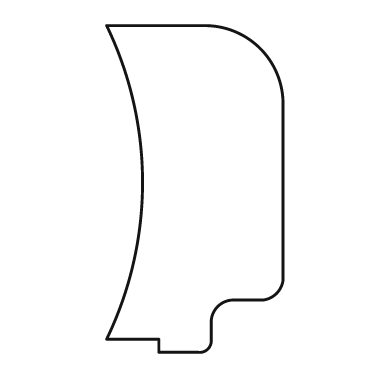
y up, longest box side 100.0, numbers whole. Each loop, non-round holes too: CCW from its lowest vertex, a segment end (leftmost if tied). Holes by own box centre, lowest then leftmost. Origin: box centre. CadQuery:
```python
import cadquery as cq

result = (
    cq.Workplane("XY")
    .moveTo(-11.0, -50.0)
    .lineTo(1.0, -50.0)
    .threePointArc((4.0, -49.0), (5.0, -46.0))
    .lineTo(5.0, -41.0)
    .threePointArc((7.0, -36.0), (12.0, -34.0))
    .lineTo(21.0, -34.0)
    .threePointArc((25.0, -32.0), (27.0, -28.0))
    .lineTo(27.0, 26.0)
    .threePointArc((20.0, 43.0), (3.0, 50.0))
    .lineTo(-27.0, 50.0)
    .threePointArc((-16.0, 2.0), (-27.0, -46.0))
    .lineTo(-11.0, -46.0)
    .close()
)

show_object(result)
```